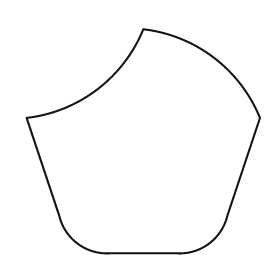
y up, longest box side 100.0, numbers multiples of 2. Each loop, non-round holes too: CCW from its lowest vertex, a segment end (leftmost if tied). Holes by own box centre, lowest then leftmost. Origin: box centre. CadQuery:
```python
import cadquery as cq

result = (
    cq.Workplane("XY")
    .moveTo(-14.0, -48.0)
    .lineTo(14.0, -48.0)
    .threePointArc((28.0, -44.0), (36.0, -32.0))
    .lineTo(50.0, 10.0)
    .threePointArc((30.0, 36.0), (0.0, 48.0))
    .threePointArc((-20.0, 22.0), (-50.0, 10.0))
    .lineTo(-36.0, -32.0)
    .threePointArc((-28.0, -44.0), (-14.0, -48.0))
    .close()
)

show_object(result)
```